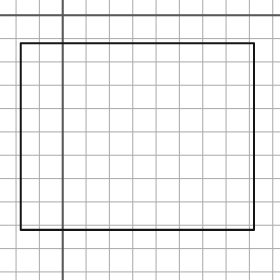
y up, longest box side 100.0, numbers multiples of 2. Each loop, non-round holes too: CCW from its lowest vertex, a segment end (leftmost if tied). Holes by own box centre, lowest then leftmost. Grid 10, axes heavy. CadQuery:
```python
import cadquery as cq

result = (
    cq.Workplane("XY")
    .moveTo(-18.0, -92.0)
    .lineTo(82.0, -92.0)
    .lineTo(82.0, -12.0)
    .lineTo(-18.0, -12.0)
    .close()
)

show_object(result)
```